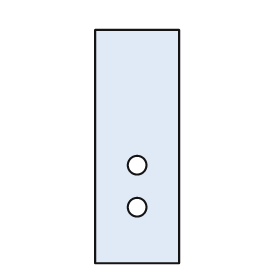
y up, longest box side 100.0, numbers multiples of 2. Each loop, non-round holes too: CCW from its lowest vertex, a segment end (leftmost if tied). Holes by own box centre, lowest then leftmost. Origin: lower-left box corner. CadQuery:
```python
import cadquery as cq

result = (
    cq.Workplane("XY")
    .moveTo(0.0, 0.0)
    .lineTo(36.0, 0.0)
    .lineTo(36.0, 100.0)
    .lineTo(0.0, 100.0)
    .close()
    .moveTo(18.0, 24.0)
    .circle(4.0)
    .moveTo(18.0, 42.0)
    .circle(4.0)
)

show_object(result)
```